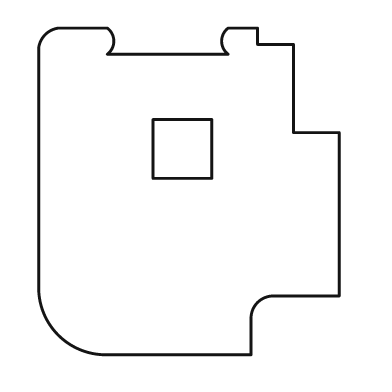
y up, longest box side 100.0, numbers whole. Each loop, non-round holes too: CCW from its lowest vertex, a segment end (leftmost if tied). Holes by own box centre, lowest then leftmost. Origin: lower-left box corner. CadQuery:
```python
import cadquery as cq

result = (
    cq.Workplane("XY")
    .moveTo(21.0, 0.0)
    .lineTo(65.0, 0.0)
    .lineTo(65.0, 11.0)
    .threePointArc((67.0, 16.0), (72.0, 18.0))
    .lineTo(92.0, 18.0)
    .lineTo(92.0, 68.0)
    .lineTo(78.0, 68.0)
    .lineTo(78.0, 95.0)
    .lineTo(67.0, 95.0)
    .lineTo(67.0, 100.0)
    .lineTo(58.0, 100.0)
    .threePointArc((56.0, 96.0), (58.0, 92.0))
    .lineTo(21.0, 92.0)
    .threePointArc((23.0, 96.0), (21.0, 100.0))
    .lineTo(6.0, 100.0)
    .threePointArc((2.0, 98.0), (0.0, 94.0))
    .lineTo(0.0, 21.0)
    .threePointArc((6.0, 6.0), (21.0, 0.0))
    .close()
    .moveTo(35.0, 54.0)
    .lineTo(53.0, 54.0)
    .lineTo(53.0, 72.0)
    .lineTo(35.0, 72.0)
    .close()
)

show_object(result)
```